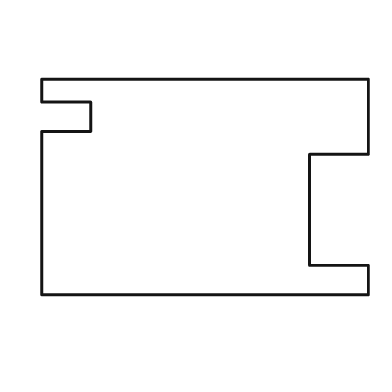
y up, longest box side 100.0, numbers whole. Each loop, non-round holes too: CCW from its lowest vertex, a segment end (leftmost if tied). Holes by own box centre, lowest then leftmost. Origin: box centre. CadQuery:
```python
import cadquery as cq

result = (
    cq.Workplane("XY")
    .moveTo(-50.0, -33.0)
    .lineTo(50.0, -33.0)
    .lineTo(50.0, -24.0)
    .lineTo(32.0, -24.0)
    .lineTo(32.0, 10.0)
    .lineTo(50.0, 10.0)
    .lineTo(50.0, 33.0)
    .lineTo(-50.0, 33.0)
    .lineTo(-50.0, 26.0)
    .lineTo(-35.0, 26.0)
    .lineTo(-35.0, 17.0)
    .lineTo(-50.0, 17.0)
    .close()
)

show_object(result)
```